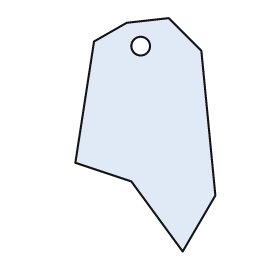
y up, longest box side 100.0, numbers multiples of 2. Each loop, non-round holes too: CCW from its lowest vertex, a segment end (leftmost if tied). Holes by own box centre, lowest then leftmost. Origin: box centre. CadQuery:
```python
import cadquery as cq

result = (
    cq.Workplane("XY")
    .moveTo(16.0, -50.0)
    .lineTo(30.0, -26.0)
    .lineTo(24.0, 36.0)
    .lineTo(10.0, 50.0)
    .lineTo(-8.0, 48.0)
    .lineTo(-22.0, 40.0)
    .lineTo(-30.0, -12.0)
    .lineTo(-6.0, -20.0)
    .close()
    .moveTo(-2.0, 38.0)
    .circle(4.0)
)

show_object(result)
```